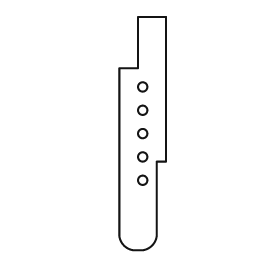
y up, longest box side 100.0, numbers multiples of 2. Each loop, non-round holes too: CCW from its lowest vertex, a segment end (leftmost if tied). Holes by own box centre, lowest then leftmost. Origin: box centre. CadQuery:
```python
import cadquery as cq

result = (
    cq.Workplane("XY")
    .moveTo(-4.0, -50.0)
    .lineTo(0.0, -50.0)
    .threePointArc((4.0, -48.0), (6.0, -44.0))
    .lineTo(6.0, -12.0)
    .lineTo(10.0, -12.0)
    .lineTo(10.0, 50.0)
    .lineTo(-2.0, 50.0)
    .lineTo(-2.0, 28.0)
    .lineTo(-10.0, 28.0)
    .lineTo(-10.0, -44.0)
    .threePointArc((-8.0, -48.0), (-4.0, -50.0))
    .close()
    .moveTo(0.0, -20.0)
    .circle(2.0)
    .moveTo(0.0, -10.0)
    .circle(2.0)
    .moveTo(0.0, 0.0)
    .circle(2.0)
    .moveTo(0.0, 10.0)
    .circle(2.0)
    .moveTo(0.0, 20.0)
    .circle(2.0)
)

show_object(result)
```